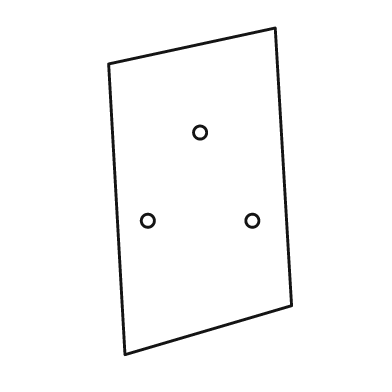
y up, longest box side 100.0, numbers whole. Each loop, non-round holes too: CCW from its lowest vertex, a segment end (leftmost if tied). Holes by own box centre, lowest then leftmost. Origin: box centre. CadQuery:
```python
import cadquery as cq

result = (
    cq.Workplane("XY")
    .moveTo(-23.0, -50.0)
    .lineTo(28.0, -35.0)
    .lineTo(23.0, 50.0)
    .lineTo(-28.0, 39.0)
    .close()
    .moveTo(-16.0, -9.0)
    .circle(2.0)
    .moveTo(16.0, -9.0)
    .circle(2.0)
    .moveTo(0.0, 18.0)
    .circle(2.0)
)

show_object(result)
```